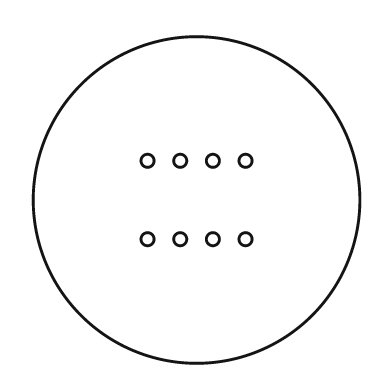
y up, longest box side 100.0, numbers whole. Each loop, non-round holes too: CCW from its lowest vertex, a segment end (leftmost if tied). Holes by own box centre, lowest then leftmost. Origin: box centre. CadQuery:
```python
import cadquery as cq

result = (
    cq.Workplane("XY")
    .moveTo(0.0, 0.0)
    .circle(50.0)
    .moveTo(-15.0, -12.0)
    .circle(2.0)
    .moveTo(-5.0, -12.0)
    .circle(2.0)
    .moveTo(5.0, -12.0)
    .circle(2.0)
    .moveTo(15.0, -12.0)
    .circle(2.0)
    .moveTo(-15.0, 12.0)
    .circle(2.0)
    .moveTo(-5.0, 12.0)
    .circle(2.0)
    .moveTo(5.0, 12.0)
    .circle(2.0)
    .moveTo(15.0, 12.0)
    .circle(2.0)
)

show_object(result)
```